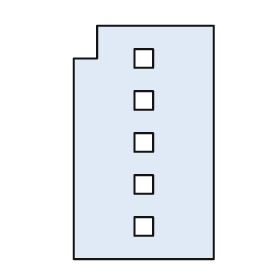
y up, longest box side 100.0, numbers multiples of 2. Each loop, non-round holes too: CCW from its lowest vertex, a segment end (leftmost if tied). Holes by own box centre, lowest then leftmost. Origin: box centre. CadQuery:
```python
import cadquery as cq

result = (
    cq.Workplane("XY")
    .moveTo(-30.0, -50.0)
    .lineTo(30.0, -50.0)
    .lineTo(30.0, 50.0)
    .lineTo(-20.0, 50.0)
    .lineTo(-20.0, 36.0)
    .lineTo(-30.0, 36.0)
    .close()
    .moveTo(-4.0, -40.0)
    .lineTo(4.0, -40.0)
    .lineTo(4.0, -32.0)
    .lineTo(-4.0, -32.0)
    .close()
    .moveTo(-4.0, -22.0)
    .lineTo(4.0, -22.0)
    .lineTo(4.0, -14.0)
    .lineTo(-4.0, -14.0)
    .close()
    .moveTo(-4.0, -4.0)
    .lineTo(4.0, -4.0)
    .lineTo(4.0, 4.0)
    .lineTo(-4.0, 4.0)
    .close()
    .moveTo(-4.0, 14.0)
    .lineTo(4.0, 14.0)
    .lineTo(4.0, 22.0)
    .lineTo(-4.0, 22.0)
    .close()
    .moveTo(-4.0, 32.0)
    .lineTo(4.0, 32.0)
    .lineTo(4.0, 40.0)
    .lineTo(-4.0, 40.0)
    .close()
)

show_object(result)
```